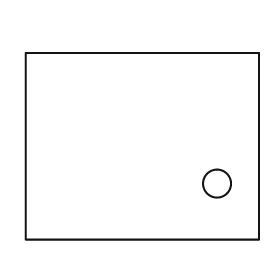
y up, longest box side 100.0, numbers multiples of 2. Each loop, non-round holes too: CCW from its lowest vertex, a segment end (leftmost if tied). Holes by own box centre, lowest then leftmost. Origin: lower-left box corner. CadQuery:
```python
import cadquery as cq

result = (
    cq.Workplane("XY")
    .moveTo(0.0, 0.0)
    .lineTo(100.0, 0.0)
    .lineTo(100.0, 80.0)
    .lineTo(0.0, 80.0)
    .close()
    .moveTo(82.0, 24.0)
    .circle(6.0)
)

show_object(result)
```